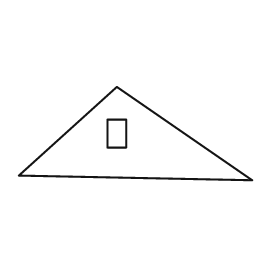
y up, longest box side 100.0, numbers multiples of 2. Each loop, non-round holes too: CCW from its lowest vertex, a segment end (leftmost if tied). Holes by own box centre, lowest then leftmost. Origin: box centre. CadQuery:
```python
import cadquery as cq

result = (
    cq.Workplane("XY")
    .moveTo(50.0, -20.0)
    .lineTo(-8.0, 20.0)
    .lineTo(-50.0, -18.0)
    .close()
    .moveTo(-12.0, -6.0)
    .lineTo(-4.0, -6.0)
    .lineTo(-4.0, 6.0)
    .lineTo(-12.0, 6.0)
    .close()
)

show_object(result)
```